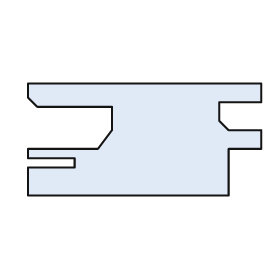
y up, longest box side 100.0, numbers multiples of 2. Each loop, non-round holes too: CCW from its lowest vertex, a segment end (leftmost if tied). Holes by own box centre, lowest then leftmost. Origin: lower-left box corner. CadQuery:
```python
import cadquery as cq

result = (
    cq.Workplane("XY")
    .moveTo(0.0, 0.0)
    .lineTo(86.0, 0.0)
    .lineTo(86.0, 20.0)
    .lineTo(100.0, 20.0)
    .lineTo(100.0, 28.0)
    .lineTo(86.0, 28.0)
    .lineTo(82.0, 32.0)
    .lineTo(82.0, 40.0)
    .lineTo(100.0, 40.0)
    .lineTo(100.0, 48.0)
    .lineTo(0.0, 48.0)
    .lineTo(0.0, 42.0)
    .lineTo(4.0, 38.0)
    .lineTo(36.0, 38.0)
    .lineTo(36.0, 28.0)
    .lineTo(30.0, 20.0)
    .lineTo(0.0, 20.0)
    .lineTo(0.0, 16.0)
    .lineTo(20.0, 16.0)
    .lineTo(20.0, 12.0)
    .lineTo(0.0, 12.0)
    .close()
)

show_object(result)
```